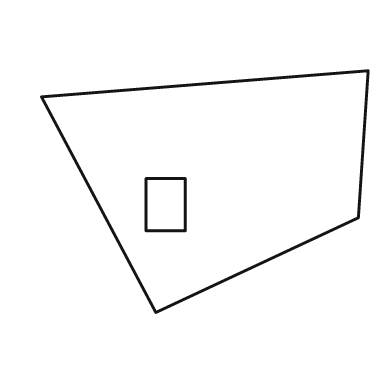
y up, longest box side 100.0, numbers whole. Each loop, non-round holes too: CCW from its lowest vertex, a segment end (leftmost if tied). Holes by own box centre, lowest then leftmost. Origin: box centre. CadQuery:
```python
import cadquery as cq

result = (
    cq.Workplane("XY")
    .moveTo(-15.0, -37.0)
    .lineTo(47.0, -8.0)
    .lineTo(50.0, 37.0)
    .lineTo(-50.0, 29.0)
    .close()
    .moveTo(-18.0, -12.0)
    .lineTo(-6.0, -12.0)
    .lineTo(-6.0, 4.0)
    .lineTo(-18.0, 4.0)
    .close()
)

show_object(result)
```